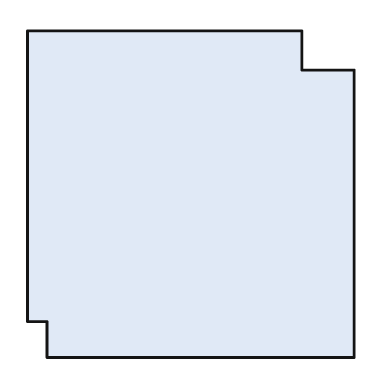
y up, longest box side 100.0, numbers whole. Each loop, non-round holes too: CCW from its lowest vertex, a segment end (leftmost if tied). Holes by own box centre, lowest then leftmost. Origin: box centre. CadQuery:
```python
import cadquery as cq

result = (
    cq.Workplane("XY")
    .moveTo(-44.0, -50.0)
    .lineTo(50.0, -50.0)
    .lineTo(50.0, 38.0)
    .lineTo(34.0, 38.0)
    .lineTo(34.0, 50.0)
    .lineTo(-50.0, 50.0)
    .lineTo(-50.0, -39.0)
    .lineTo(-44.0, -39.0)
    .close()
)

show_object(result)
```